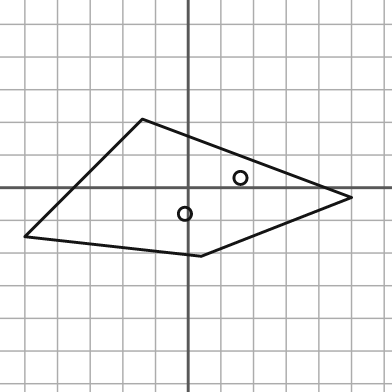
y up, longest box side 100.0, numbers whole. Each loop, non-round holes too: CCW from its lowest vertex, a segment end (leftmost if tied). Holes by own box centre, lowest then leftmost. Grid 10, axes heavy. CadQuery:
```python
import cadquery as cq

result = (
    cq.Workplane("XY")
    .moveTo(4.0, -21.0)
    .lineTo(50.0, -3.0)
    .lineTo(-14.0, 21.0)
    .lineTo(-50.0, -15.0)
    .close()
    .moveTo(-1.0, -8.0)
    .circle(2.0)
    .moveTo(16.0, 3.0)
    .circle(2.0)
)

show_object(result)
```